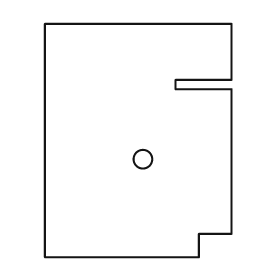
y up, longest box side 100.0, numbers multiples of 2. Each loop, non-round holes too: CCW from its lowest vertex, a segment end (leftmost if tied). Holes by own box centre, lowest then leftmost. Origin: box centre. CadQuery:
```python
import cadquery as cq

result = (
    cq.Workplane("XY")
    .moveTo(-40.0, -50.0)
    .lineTo(26.0, -50.0)
    .lineTo(26.0, -40.0)
    .lineTo(40.0, -40.0)
    .lineTo(40.0, 22.0)
    .lineTo(16.0, 22.0)
    .lineTo(16.0, 26.0)
    .lineTo(40.0, 26.0)
    .lineTo(40.0, 50.0)
    .lineTo(-40.0, 50.0)
    .close()
    .moveTo(2.0, -8.0)
    .circle(4.0)
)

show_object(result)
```